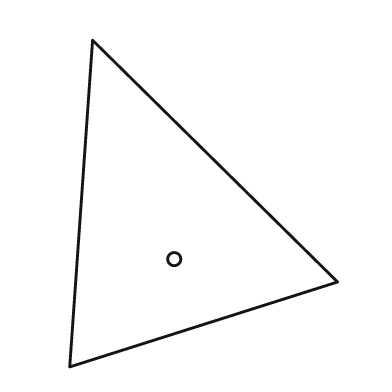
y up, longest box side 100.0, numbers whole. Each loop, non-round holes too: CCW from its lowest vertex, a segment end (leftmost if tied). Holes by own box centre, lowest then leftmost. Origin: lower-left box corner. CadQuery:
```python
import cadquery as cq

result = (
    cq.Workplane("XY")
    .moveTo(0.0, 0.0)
    .lineTo(82.0, 26.0)
    .lineTo(7.0, 100.0)
    .close()
    .moveTo(32.0, 33.0)
    .circle(2.0)
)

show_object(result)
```